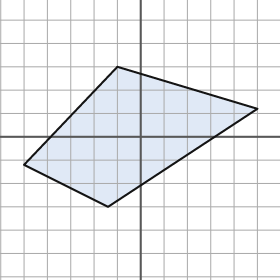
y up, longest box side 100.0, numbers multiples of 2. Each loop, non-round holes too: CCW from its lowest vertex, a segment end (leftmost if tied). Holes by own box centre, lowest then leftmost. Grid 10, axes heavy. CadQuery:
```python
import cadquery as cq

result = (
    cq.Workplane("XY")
    .moveTo(-14.0, -30.0)
    .lineTo(50.0, 12.0)
    .lineTo(-10.0, 30.0)
    .lineTo(-50.0, -12.0)
    .close()
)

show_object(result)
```